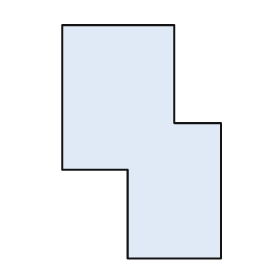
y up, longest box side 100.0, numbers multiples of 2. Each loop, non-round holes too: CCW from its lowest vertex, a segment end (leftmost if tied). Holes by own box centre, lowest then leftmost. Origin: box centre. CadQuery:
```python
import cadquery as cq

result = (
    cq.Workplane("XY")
    .moveTo(-6.0, -50.0)
    .lineTo(34.0, -50.0)
    .lineTo(34.0, 8.0)
    .lineTo(14.0, 8.0)
    .lineTo(14.0, 50.0)
    .lineTo(-34.0, 50.0)
    .lineTo(-34.0, -12.0)
    .lineTo(-6.0, -12.0)
    .close()
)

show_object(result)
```